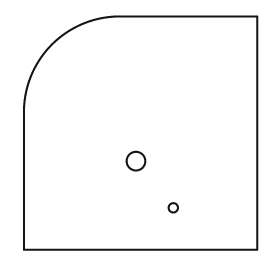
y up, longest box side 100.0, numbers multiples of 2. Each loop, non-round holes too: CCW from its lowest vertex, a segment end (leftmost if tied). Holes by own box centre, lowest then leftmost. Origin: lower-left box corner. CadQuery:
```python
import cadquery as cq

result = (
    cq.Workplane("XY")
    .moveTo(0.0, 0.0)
    .lineTo(100.0, 0.0)
    .lineTo(100.0, 100.0)
    .lineTo(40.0, 100.0)
    .threePointArc((12.0, 88.0), (0.0, 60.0))
    .close()
    .moveTo(64.0, 18.0)
    .circle(2.0)
    .moveTo(48.0, 38.0)
    .circle(4.0)
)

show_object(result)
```